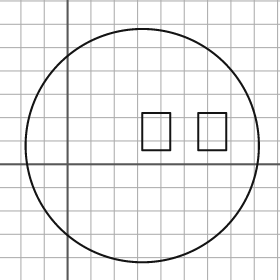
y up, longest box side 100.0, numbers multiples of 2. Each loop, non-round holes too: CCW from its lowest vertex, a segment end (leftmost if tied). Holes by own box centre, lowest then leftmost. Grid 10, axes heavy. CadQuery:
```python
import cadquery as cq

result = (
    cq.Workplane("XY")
    .moveTo(32.0, 8.0)
    .circle(50.0)
    .moveTo(32.0, 6.0)
    .lineTo(44.0, 6.0)
    .lineTo(44.0, 22.0)
    .lineTo(32.0, 22.0)
    .close()
    .moveTo(56.0, 6.0)
    .lineTo(68.0, 6.0)
    .lineTo(68.0, 22.0)
    .lineTo(56.0, 22.0)
    .close()
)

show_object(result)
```